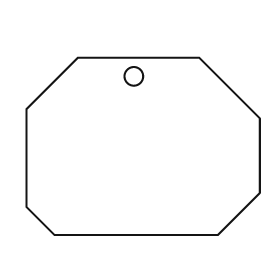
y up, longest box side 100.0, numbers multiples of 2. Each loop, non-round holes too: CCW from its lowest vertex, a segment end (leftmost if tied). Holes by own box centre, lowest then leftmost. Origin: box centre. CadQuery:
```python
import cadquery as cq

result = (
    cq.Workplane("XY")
    .moveTo(-38.0, -38.0)
    .lineTo(32.0, -38.0)
    .lineTo(50.0, -20.0)
    .lineTo(50.0, 12.0)
    .lineTo(24.0, 38.0)
    .lineTo(-28.0, 38.0)
    .lineTo(-50.0, 16.0)
    .lineTo(-50.0, -26.0)
    .close()
    .moveTo(-4.0, 30.0)
    .circle(4.0)
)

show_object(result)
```